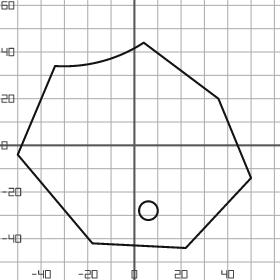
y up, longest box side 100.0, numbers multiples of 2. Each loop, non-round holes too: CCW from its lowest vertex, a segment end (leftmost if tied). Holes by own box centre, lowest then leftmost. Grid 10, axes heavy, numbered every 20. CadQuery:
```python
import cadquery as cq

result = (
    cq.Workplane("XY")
    .moveTo(22.0, -44.0)
    .lineTo(50.0, -14.0)
    .lineTo(36.0, 20.0)
    .lineTo(4.0, 44.0)
    .threePointArc((-14.0, 36.0), (-34.0, 34.0))
    .lineTo(-50.0, -4.0)
    .lineTo(-18.0, -42.0)
    .close()
    .moveTo(6.0, -28.0)
    .circle(4.0)
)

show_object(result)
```